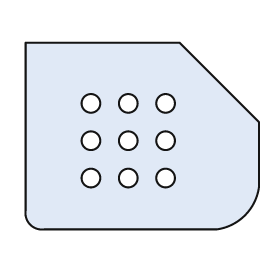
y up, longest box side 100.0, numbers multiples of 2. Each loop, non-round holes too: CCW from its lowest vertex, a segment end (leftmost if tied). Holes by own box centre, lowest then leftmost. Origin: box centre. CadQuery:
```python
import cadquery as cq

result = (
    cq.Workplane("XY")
    .moveTo(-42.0, -40.0)
    .lineTo(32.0, -40.0)
    .threePointArc((44.0, -34.0), (50.0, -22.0))
    .lineTo(50.0, 6.0)
    .lineTo(16.0, 40.0)
    .lineTo(-50.0, 40.0)
    .lineTo(-50.0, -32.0)
    .threePointArc((-48.0, -38.0), (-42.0, -40.0))
    .close()
    .moveTo(-22.0, -18.0)
    .circle(4.0)
    .moveTo(-6.0, -18.0)
    .circle(4.0)
    .moveTo(10.0, -18.0)
    .circle(4.0)
    .moveTo(-22.0, -2.0)
    .circle(4.0)
    .moveTo(-6.0, -2.0)
    .circle(4.0)
    .moveTo(10.0, -2.0)
    .circle(4.0)
    .moveTo(-22.0, 14.0)
    .circle(4.0)
    .moveTo(-6.0, 14.0)
    .circle(4.0)
    .moveTo(10.0, 14.0)
    .circle(4.0)
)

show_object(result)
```